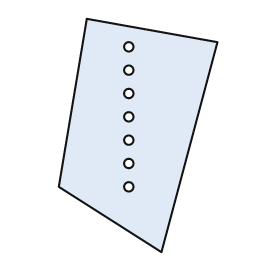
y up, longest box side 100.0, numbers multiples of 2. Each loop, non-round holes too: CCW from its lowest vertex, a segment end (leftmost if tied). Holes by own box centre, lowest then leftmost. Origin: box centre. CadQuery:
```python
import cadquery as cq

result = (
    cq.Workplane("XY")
    .moveTo(10.0, -50.0)
    .lineTo(34.0, 40.0)
    .lineTo(-22.0, 50.0)
    .lineTo(-34.0, -22.0)
    .close()
    .moveTo(-4.0, -22.0)
    .circle(2.0)
    .moveTo(-4.0, -12.0)
    .circle(2.0)
    .moveTo(-4.0, -2.0)
    .circle(2.0)
    .moveTo(-4.0, 8.0)
    .circle(2.0)
    .moveTo(-4.0, 18.0)
    .circle(2.0)
    .moveTo(-4.0, 28.0)
    .circle(2.0)
    .moveTo(-4.0, 38.0)
    .circle(2.0)
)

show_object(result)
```